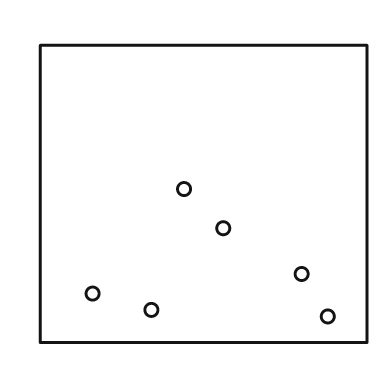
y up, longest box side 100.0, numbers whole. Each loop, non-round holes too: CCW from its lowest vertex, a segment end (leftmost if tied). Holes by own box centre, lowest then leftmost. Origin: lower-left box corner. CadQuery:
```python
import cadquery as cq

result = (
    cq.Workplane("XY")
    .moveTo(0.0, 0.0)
    .lineTo(100.0, 0.0)
    .lineTo(100.0, 91.0)
    .lineTo(0.0, 91.0)
    .close()
    .moveTo(88.0, 8.0)
    .circle(2.0)
    .moveTo(34.0, 10.0)
    .circle(2.0)
    .moveTo(16.0, 15.0)
    .circle(2.0)
    .moveTo(80.0, 21.0)
    .circle(2.0)
    .moveTo(56.0, 35.0)
    .circle(2.0)
    .moveTo(44.0, 47.0)
    .circle(2.0)
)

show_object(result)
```